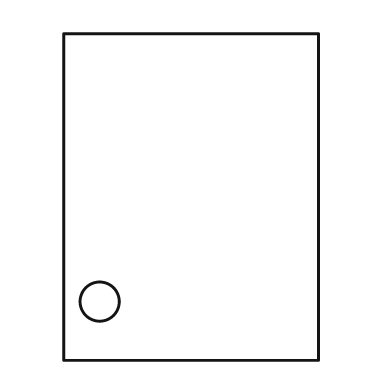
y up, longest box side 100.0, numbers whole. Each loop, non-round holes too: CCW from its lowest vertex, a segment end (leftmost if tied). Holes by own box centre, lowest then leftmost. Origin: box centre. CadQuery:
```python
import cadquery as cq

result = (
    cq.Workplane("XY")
    .moveTo(-39.0, -50.0)
    .lineTo(39.0, -50.0)
    .lineTo(39.0, 50.0)
    .lineTo(-39.0, 50.0)
    .close()
    .moveTo(-28.0, -32.0)
    .circle(6.0)
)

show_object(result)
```